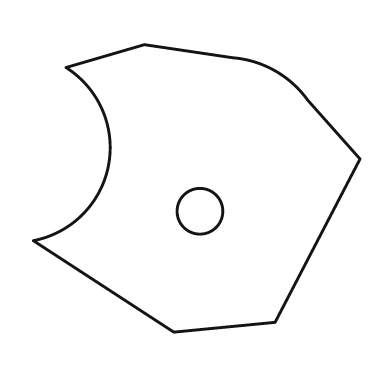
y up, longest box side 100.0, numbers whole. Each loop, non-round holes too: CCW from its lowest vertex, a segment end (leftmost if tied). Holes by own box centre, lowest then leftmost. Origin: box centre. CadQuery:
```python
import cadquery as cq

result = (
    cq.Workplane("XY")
    .moveTo(-7.0, -44.0)
    .lineTo(24.0, -41.0)
    .lineTo(50.0, 9.0)
    .lineTo(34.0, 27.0)
    .threePointArc((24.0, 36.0), (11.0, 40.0))
    .lineTo(-16.0, 44.0)
    .lineTo(-40.0, 37.0)
    .threePointArc((-27.0, 7.0), (-50.0, -16.0))
    .close()
    .moveTo(1.0, -7.0)
    .circle(7.0)
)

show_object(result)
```